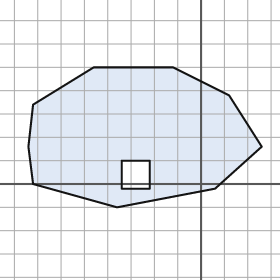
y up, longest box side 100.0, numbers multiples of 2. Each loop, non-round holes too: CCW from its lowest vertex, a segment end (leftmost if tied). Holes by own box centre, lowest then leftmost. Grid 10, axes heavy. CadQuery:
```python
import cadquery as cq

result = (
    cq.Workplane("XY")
    .moveTo(-36.0, -10.0)
    .lineTo(6.0, -2.0)
    .lineTo(26.0, 16.0)
    .lineTo(12.0, 38.0)
    .lineTo(-12.0, 50.0)
    .lineTo(-46.0, 50.0)
    .lineTo(-72.0, 34.0)
    .lineTo(-74.0, 16.0)
    .lineTo(-72.0, 0.0)
    .close()
    .moveTo(-34.0, -2.0)
    .lineTo(-22.0, -2.0)
    .lineTo(-22.0, 10.0)
    .lineTo(-34.0, 10.0)
    .close()
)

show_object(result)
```